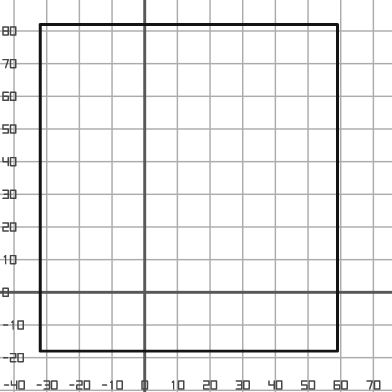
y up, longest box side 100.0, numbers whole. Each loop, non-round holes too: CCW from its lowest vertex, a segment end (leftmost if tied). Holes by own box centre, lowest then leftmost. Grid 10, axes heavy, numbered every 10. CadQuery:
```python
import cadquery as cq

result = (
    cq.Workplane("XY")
    .moveTo(-32.0, -18.0)
    .lineTo(59.0, -18.0)
    .lineTo(59.0, 82.0)
    .lineTo(-32.0, 82.0)
    .close()
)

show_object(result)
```